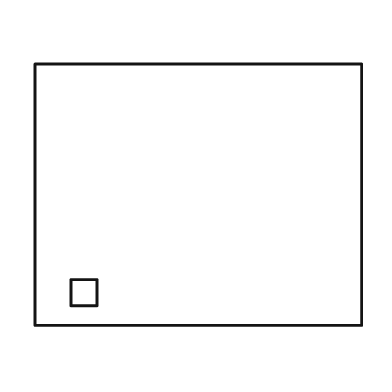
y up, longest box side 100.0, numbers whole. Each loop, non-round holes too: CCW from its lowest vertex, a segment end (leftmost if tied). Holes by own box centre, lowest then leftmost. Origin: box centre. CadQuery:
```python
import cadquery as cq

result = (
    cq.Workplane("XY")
    .moveTo(-50.0, -40.0)
    .lineTo(50.0, -40.0)
    .lineTo(50.0, 40.0)
    .lineTo(-50.0, 40.0)
    .close()
    .moveTo(-39.0, -34.0)
    .lineTo(-31.0, -34.0)
    .lineTo(-31.0, -26.0)
    .lineTo(-39.0, -26.0)
    .close()
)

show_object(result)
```